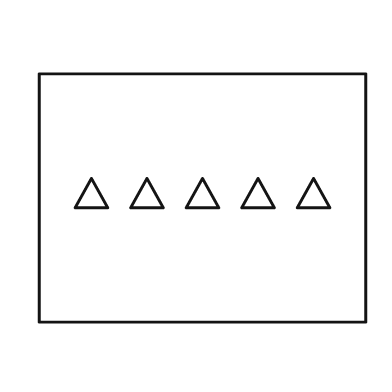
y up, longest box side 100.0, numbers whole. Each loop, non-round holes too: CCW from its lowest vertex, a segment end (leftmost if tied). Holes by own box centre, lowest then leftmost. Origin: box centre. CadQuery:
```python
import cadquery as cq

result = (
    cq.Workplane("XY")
    .moveTo(-50.0, -38.0)
    .lineTo(50.0, -38.0)
    .lineTo(50.0, 38.0)
    .lineTo(-50.0, 38.0)
    .close()
    .moveTo(-39.0, -3.0)
    .lineTo(-29.0, -3.0)
    .lineTo(-34.0, 6.0)
    .close()
    .moveTo(-22.0, -3.0)
    .lineTo(-12.0, -3.0)
    .lineTo(-17.0, 6.0)
    .close()
    .moveTo(-5.0, -3.0)
    .lineTo(5.0, -3.0)
    .lineTo(0.0, 6.0)
    .close()
    .moveTo(12.0, -3.0)
    .lineTo(22.0, -3.0)
    .lineTo(17.0, 6.0)
    .close()
    .moveTo(29.0, -3.0)
    .lineTo(39.0, -3.0)
    .lineTo(34.0, 6.0)
    .close()
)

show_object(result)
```